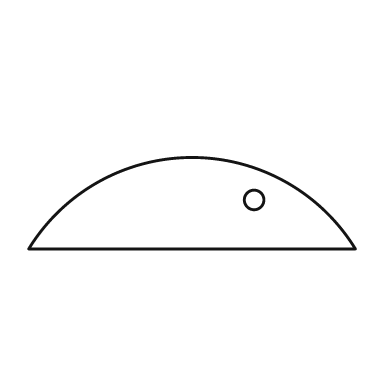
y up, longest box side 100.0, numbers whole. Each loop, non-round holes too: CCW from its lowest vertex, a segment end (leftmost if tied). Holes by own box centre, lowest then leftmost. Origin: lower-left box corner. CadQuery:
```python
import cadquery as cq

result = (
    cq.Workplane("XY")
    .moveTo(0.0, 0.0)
    .lineTo(100.0, 0.0)
    .threePointArc((50.0, 28.0), (0.0, 0.0))
    .close()
    .moveTo(69.0, 15.0)
    .circle(3.0)
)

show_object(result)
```